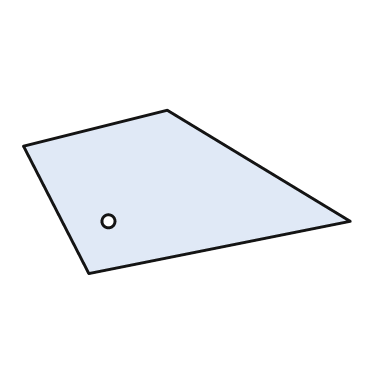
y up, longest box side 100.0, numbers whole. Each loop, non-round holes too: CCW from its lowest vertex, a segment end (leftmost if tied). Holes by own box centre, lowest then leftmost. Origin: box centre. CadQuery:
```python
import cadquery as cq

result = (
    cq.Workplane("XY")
    .moveTo(-30.0, -25.0)
    .lineTo(50.0, -9.0)
    .lineTo(-6.0, 25.0)
    .lineTo(-50.0, 14.0)
    .close()
    .moveTo(-24.0, -9.0)
    .circle(2.0)
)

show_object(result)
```